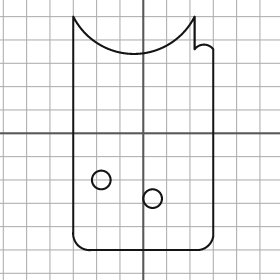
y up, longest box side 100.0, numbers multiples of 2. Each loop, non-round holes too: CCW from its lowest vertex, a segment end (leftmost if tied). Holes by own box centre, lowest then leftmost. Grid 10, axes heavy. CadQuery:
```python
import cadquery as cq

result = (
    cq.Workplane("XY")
    .moveTo(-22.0, -50.0)
    .lineTo(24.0, -50.0)
    .threePointArc((28.0, -48.0), (30.0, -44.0))
    .lineTo(30.0, 36.0)
    .threePointArc((26.0, 38.0), (22.0, 36.0))
    .lineTo(22.0, 50.0)
    .threePointArc((-4.0, 34.0), (-30.0, 50.0))
    .lineTo(-30.0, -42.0)
    .threePointArc((-28.0, -48.0), (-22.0, -50.0))
    .close()
    .moveTo(4.0, -28.0)
    .circle(4.0)
    .moveTo(-18.0, -20.0)
    .circle(4.0)
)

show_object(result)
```